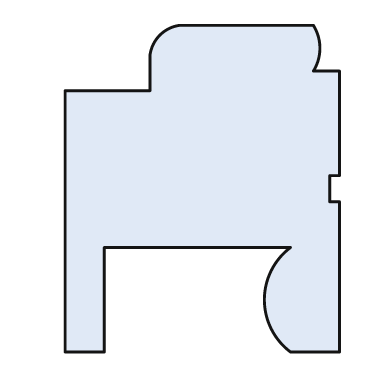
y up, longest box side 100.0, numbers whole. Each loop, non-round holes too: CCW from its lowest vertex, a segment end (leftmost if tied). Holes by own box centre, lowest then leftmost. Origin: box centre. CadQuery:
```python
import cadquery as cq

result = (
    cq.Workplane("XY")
    .moveTo(-42.0, -50.0)
    .lineTo(-30.0, -50.0)
    .lineTo(-30.0, -18.0)
    .lineTo(27.0, -18.0)
    .threePointArc((19.0, -34.0), (27.0, -50.0))
    .lineTo(42.0, -50.0)
    .lineTo(42.0, -4.0)
    .lineTo(39.0, -4.0)
    .lineTo(39.0, 4.0)
    .lineTo(42.0, 4.0)
    .lineTo(42.0, 36.0)
    .lineTo(34.0, 36.0)
    .threePointArc((36.0, 43.0), (34.0, 50.0))
    .lineTo(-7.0, 50.0)
    .threePointArc((-13.0, 47.0), (-16.0, 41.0))
    .lineTo(-16.0, 30.0)
    .lineTo(-42.0, 30.0)
    .close()
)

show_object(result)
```